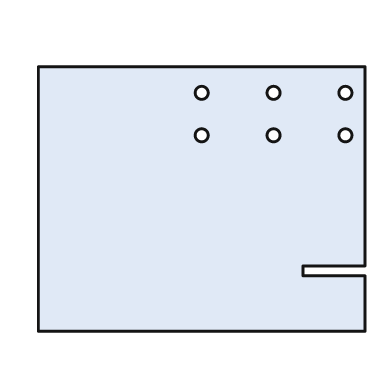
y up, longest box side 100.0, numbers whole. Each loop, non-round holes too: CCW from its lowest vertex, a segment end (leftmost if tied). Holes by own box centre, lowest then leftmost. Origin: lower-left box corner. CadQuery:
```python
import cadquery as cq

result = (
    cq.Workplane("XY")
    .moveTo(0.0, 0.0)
    .lineTo(100.0, 0.0)
    .lineTo(100.0, 17.0)
    .lineTo(81.0, 17.0)
    .lineTo(81.0, 20.0)
    .lineTo(100.0, 20.0)
    .lineTo(100.0, 81.0)
    .lineTo(0.0, 81.0)
    .close()
    .moveTo(50.0, 60.0)
    .circle(2.0)
    .moveTo(72.0, 60.0)
    .circle(2.0)
    .moveTo(94.0, 60.0)
    .circle(2.0)
    .moveTo(50.0, 73.0)
    .circle(2.0)
    .moveTo(72.0, 73.0)
    .circle(2.0)
    .moveTo(94.0, 73.0)
    .circle(2.0)
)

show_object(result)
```